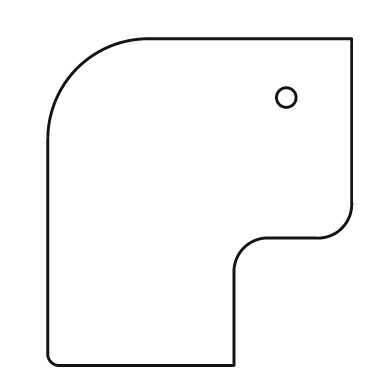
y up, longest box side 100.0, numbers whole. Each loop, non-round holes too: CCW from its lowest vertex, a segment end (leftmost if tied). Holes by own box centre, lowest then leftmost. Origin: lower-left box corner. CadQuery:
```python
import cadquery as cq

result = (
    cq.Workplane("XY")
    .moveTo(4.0, 0.0)
    .lineTo(57.0, 0.0)
    .lineTo(57.0, 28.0)
    .threePointArc((60.0, 36.0), (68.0, 39.0))
    .lineTo(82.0, 39.0)
    .threePointArc((90.0, 42.0), (93.0, 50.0))
    .lineTo(93.0, 100.0)
    .lineTo(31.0, 100.0)
    .threePointArc((9.0, 91.0), (0.0, 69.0))
    .lineTo(0.0, 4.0)
    .threePointArc((1.0, 1.0), (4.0, 0.0))
    .close()
    .moveTo(73.0, 82.0)
    .circle(3.0)
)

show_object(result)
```